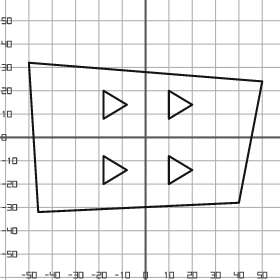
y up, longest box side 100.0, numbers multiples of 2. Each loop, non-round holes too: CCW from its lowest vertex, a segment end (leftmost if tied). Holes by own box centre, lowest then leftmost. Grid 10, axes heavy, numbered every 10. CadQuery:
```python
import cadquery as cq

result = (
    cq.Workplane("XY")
    .moveTo(-46.0, -32.0)
    .lineTo(40.0, -28.0)
    .lineTo(50.0, 24.0)
    .lineTo(-50.0, 32.0)
    .close()
    .moveTo(-18.0, -20.0)
    .lineTo(-8.0, -14.0)
    .lineTo(-18.0, -8.0)
    .close()
    .moveTo(10.0, -20.0)
    .lineTo(20.0, -14.0)
    .lineTo(10.0, -8.0)
    .close()
    .moveTo(-18.0, 8.0)
    .lineTo(-8.0, 14.0)
    .lineTo(-18.0, 20.0)
    .close()
    .moveTo(10.0, 8.0)
    .lineTo(20.0, 14.0)
    .lineTo(10.0, 20.0)
    .close()
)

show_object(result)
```